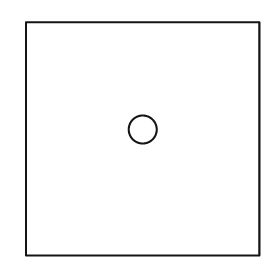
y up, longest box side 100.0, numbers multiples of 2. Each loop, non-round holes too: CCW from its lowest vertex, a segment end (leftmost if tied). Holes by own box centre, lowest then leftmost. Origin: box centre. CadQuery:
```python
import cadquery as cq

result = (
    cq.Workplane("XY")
    .moveTo(-50.0, -50.0)
    .lineTo(50.0, -50.0)
    .lineTo(50.0, 50.0)
    .lineTo(-50.0, 50.0)
    .close()
    .moveTo(0.0, 4.0)
    .circle(6.0)
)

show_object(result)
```